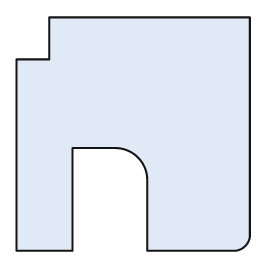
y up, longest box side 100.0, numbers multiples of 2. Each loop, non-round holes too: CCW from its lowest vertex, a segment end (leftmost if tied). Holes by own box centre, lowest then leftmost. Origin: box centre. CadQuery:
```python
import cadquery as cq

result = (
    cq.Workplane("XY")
    .moveTo(-50.0, -50.0)
    .lineTo(-26.0, -50.0)
    .lineTo(-26.0, -6.0)
    .lineTo(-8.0, -6.0)
    .threePointArc((2.0, -10.0), (6.0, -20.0))
    .lineTo(6.0, -50.0)
    .lineTo(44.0, -50.0)
    .threePointArc((48.0, -48.0), (50.0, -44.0))
    .lineTo(50.0, 50.0)
    .lineTo(-36.0, 50.0)
    .lineTo(-36.0, 32.0)
    .lineTo(-50.0, 32.0)
    .close()
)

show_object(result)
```